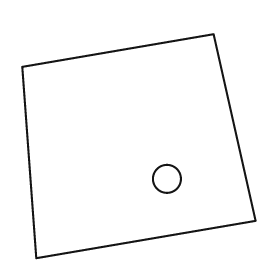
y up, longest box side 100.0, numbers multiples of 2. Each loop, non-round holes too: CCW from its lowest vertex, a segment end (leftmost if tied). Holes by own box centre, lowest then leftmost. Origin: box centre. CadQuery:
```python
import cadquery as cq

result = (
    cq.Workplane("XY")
    .moveTo(-44.0, -48.0)
    .lineTo(50.0, -32.0)
    .lineTo(32.0, 48.0)
    .lineTo(-50.0, 34.0)
    .close()
    .moveTo(12.0, -14.0)
    .circle(6.0)
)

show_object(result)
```